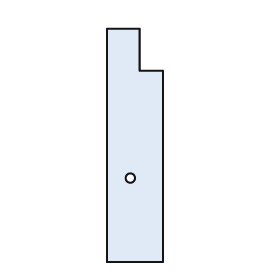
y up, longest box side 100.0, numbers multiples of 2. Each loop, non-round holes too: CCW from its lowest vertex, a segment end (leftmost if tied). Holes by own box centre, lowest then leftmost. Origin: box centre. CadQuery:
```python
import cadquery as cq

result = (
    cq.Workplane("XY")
    .moveTo(-12.0, -50.0)
    .lineTo(12.0, -50.0)
    .lineTo(12.0, 32.0)
    .lineTo(2.0, 32.0)
    .lineTo(2.0, 50.0)
    .lineTo(-12.0, 50.0)
    .close()
    .moveTo(-2.0, -14.0)
    .circle(2.0)
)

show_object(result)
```